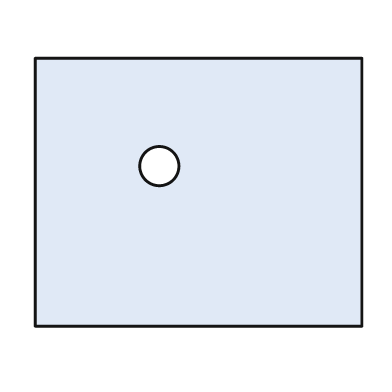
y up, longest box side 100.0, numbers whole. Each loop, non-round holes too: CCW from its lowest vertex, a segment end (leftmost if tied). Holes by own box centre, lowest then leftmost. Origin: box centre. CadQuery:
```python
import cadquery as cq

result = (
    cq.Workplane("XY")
    .moveTo(-50.0, -41.0)
    .lineTo(50.0, -41.0)
    .lineTo(50.0, 41.0)
    .lineTo(-50.0, 41.0)
    .close()
    .moveTo(-12.0, 8.0)
    .circle(6.0)
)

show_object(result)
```